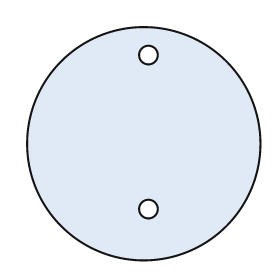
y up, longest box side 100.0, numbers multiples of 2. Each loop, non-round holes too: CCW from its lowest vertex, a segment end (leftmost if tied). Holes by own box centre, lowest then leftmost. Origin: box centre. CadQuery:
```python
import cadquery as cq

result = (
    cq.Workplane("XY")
    .moveTo(0.0, 0.0)
    .circle(50.0)
    .moveTo(2.0, -28.0)
    .circle(4.0)
    .moveTo(2.0, 38.0)
    .circle(4.0)
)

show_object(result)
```